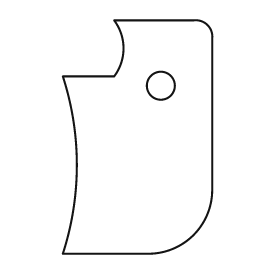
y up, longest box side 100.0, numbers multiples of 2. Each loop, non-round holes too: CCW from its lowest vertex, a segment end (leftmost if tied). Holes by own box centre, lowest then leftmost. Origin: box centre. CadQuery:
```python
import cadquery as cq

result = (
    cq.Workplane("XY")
    .moveTo(-32.0, -50.0)
    .lineTo(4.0, -50.0)
    .threePointArc((24.0, -42.0), (32.0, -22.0))
    .lineTo(32.0, 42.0)
    .threePointArc((30.0, 48.0), (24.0, 50.0))
    .lineTo(-10.0, 50.0)
    .threePointArc((-6.0, 38.0), (-10.0, 26.0))
    .lineTo(-32.0, 26.0)
    .threePointArc((-26.0, -12.0), (-32.0, -50.0))
    .close()
    .moveTo(10.0, 22.0)
    .circle(6.0)
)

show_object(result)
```